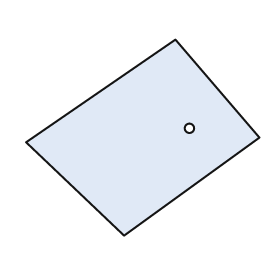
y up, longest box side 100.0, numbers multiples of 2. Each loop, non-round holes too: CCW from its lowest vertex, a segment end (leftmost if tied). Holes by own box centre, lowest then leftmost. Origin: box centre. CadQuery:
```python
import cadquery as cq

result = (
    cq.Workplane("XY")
    .moveTo(-8.0, -42.0)
    .lineTo(50.0, 0.0)
    .lineTo(14.0, 42.0)
    .lineTo(-50.0, -2.0)
    .close()
    .moveTo(20.0, 4.0)
    .circle(2.0)
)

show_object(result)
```